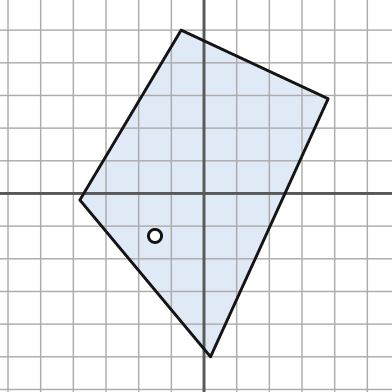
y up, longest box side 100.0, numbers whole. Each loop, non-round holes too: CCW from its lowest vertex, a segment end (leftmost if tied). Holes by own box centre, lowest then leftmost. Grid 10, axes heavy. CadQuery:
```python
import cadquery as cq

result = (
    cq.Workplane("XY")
    .moveTo(2.0, -50.0)
    .lineTo(38.0, 29.0)
    .lineTo(-7.0, 50.0)
    .lineTo(-38.0, -2.0)
    .close()
    .moveTo(-15.0, -13.0)
    .circle(2.0)
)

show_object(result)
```